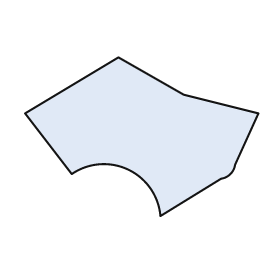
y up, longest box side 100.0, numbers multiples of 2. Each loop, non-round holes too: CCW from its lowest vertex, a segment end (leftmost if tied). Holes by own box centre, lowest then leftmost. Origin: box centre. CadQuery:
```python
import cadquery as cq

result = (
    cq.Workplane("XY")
    .moveTo(8.0, -34.0)
    .lineTo(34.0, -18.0)
    .threePointArc((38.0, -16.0), (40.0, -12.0))
    .lineTo(50.0, 10.0)
    .lineTo(18.0, 18.0)
    .lineTo(-10.0, 34.0)
    .lineTo(-50.0, 10.0)
    .lineTo(-30.0, -16.0)
    .threePointArc((-6.0, -14.0), (8.0, -34.0))
    .close()
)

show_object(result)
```